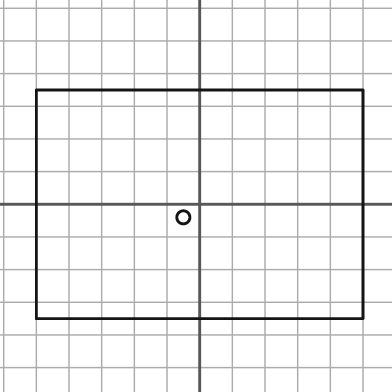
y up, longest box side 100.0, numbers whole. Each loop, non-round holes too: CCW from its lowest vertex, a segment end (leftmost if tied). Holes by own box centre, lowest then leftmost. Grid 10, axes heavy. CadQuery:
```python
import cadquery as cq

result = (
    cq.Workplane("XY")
    .moveTo(-50.0, -35.0)
    .lineTo(50.0, -35.0)
    .lineTo(50.0, 35.0)
    .lineTo(-50.0, 35.0)
    .close()
    .moveTo(-5.0, -4.0)
    .circle(2.0)
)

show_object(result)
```